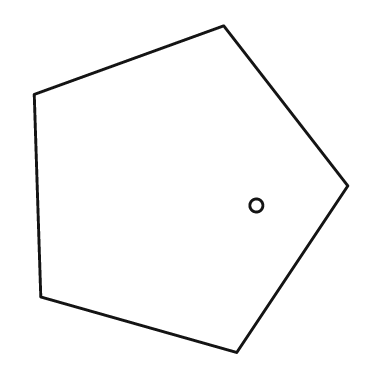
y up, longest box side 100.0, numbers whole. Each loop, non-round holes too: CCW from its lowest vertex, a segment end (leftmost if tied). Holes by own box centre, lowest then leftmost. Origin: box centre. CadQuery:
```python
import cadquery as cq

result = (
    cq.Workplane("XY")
    .moveTo(14.0, -50.0)
    .lineTo(48.0, 1.0)
    .lineTo(10.0, 50.0)
    .lineTo(-48.0, 29.0)
    .lineTo(-46.0, -33.0)
    .close()
    .moveTo(20.0, -5.0)
    .circle(2.0)
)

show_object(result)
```